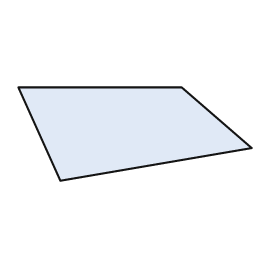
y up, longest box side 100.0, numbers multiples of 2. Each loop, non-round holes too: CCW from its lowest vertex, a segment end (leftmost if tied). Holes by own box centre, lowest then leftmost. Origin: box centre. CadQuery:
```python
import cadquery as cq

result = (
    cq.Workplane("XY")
    .moveTo(-32.0, -20.0)
    .lineTo(50.0, -6.0)
    .lineTo(20.0, 20.0)
    .lineTo(-50.0, 20.0)
    .close()
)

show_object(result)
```